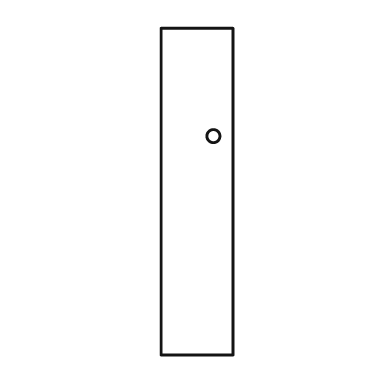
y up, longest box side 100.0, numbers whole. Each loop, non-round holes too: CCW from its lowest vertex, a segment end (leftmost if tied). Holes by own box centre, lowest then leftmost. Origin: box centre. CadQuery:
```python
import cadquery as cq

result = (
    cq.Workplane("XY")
    .moveTo(-11.0, -50.0)
    .lineTo(11.0, -50.0)
    .lineTo(11.0, 50.0)
    .lineTo(-11.0, 50.0)
    .close()
    .moveTo(5.0, 17.0)
    .circle(2.0)
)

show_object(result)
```